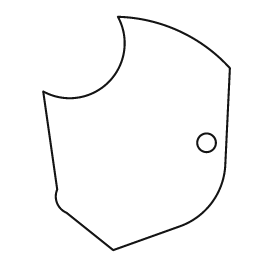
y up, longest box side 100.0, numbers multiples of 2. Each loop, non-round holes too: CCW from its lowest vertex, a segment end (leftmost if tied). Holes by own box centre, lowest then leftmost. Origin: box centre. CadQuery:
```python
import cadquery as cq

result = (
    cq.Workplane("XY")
    .moveTo(-10.0, -50.0)
    .lineTo(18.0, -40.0)
    .threePointArc((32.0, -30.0), (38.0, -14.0))
    .lineTo(40.0, 28.0)
    .threePointArc((18.0, 44.0), (-8.0, 50.0))
    .threePointArc((-12.0, 22.0), (-40.0, 18.0))
    .lineTo(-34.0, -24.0)
    .threePointArc((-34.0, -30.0), (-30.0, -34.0))
    .close()
    .moveTo(30.0, -4.0)
    .circle(4.0)
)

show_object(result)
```